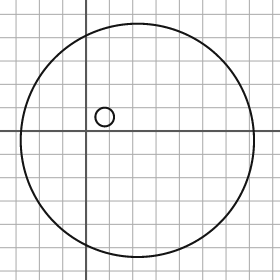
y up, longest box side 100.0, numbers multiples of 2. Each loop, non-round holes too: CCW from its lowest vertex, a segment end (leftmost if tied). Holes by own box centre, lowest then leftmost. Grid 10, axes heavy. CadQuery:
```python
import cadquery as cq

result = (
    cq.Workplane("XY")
    .moveTo(22.0, -4.0)
    .circle(50.0)
    .moveTo(8.0, 6.0)
    .circle(4.0)
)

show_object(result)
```